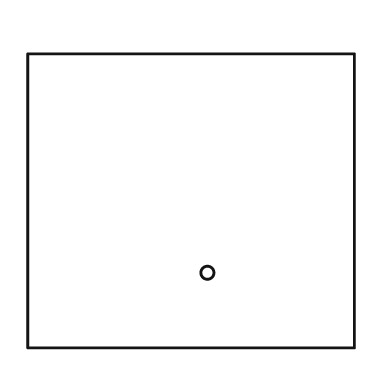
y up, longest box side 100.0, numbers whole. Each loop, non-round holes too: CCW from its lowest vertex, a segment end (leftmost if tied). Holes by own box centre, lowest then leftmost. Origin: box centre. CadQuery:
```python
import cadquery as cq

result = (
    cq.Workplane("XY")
    .moveTo(-50.0, -45.0)
    .lineTo(50.0, -45.0)
    .lineTo(50.0, 45.0)
    .lineTo(-50.0, 45.0)
    .close()
    .moveTo(5.0, -22.0)
    .circle(2.0)
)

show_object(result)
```